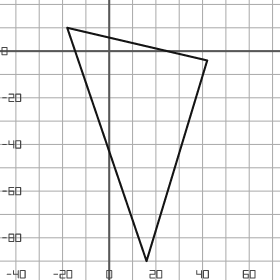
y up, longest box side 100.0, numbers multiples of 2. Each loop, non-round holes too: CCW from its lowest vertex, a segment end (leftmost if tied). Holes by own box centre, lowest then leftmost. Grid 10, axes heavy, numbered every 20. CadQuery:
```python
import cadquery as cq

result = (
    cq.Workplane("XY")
    .moveTo(16.0, -90.0)
    .lineTo(42.0, -4.0)
    .lineTo(-18.0, 10.0)
    .close()
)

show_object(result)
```